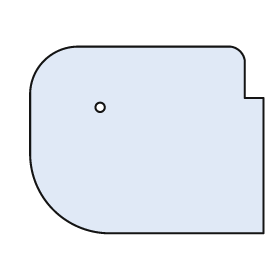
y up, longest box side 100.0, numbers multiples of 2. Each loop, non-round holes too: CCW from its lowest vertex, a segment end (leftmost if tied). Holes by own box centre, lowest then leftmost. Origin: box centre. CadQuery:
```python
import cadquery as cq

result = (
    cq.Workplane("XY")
    .moveTo(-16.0, -40.0)
    .lineTo(50.0, -40.0)
    .lineTo(50.0, 18.0)
    .lineTo(42.0, 18.0)
    .lineTo(42.0, 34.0)
    .threePointArc((40.0, 38.0), (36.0, 40.0))
    .lineTo(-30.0, 40.0)
    .threePointArc((-44.0, 34.0), (-50.0, 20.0))
    .lineTo(-50.0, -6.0)
    .threePointArc((-40.0, -30.0), (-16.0, -40.0))
    .close()
    .moveTo(-20.0, 14.0)
    .circle(2.0)
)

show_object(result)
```